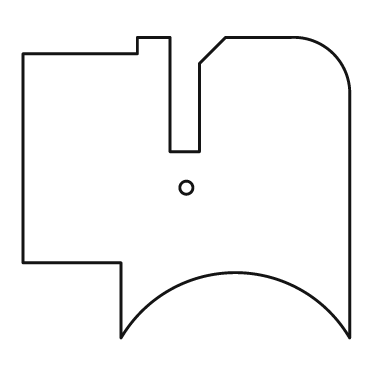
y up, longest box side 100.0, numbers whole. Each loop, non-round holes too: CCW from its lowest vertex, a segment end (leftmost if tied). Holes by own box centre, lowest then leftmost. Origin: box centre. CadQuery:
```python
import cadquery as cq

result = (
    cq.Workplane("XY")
    .moveTo(-20.0, -46.0)
    .threePointArc((15.0, -26.0), (50.0, -46.0))
    .lineTo(50.0, 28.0)
    .threePointArc((45.0, 41.0), (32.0, 46.0))
    .lineTo(12.0, 46.0)
    .lineTo(4.0, 38.0)
    .lineTo(4.0, 11.0)
    .lineTo(-5.0, 11.0)
    .lineTo(-5.0, 46.0)
    .lineTo(-15.0, 46.0)
    .lineTo(-15.0, 41.0)
    .lineTo(-50.0, 41.0)
    .lineTo(-50.0, -23.0)
    .lineTo(-20.0, -23.0)
    .close()
    .moveTo(0.0, 0.0)
    .circle(2.0)
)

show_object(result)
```